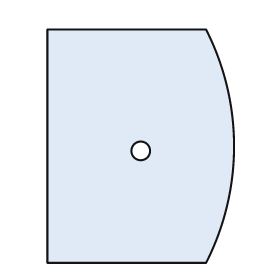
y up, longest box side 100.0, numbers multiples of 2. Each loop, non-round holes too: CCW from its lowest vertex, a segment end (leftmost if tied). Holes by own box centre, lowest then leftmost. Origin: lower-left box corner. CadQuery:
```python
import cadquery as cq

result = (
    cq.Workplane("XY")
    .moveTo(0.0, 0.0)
    .lineTo(68.0, 0.0)
    .threePointArc((80.0, 50.0), (68.0, 100.0))
    .lineTo(0.0, 100.0)
    .close()
    .moveTo(40.0, 48.0)
    .circle(4.0)
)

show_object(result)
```